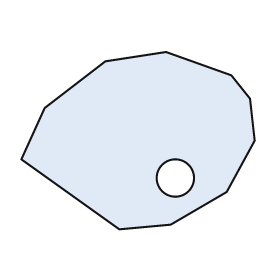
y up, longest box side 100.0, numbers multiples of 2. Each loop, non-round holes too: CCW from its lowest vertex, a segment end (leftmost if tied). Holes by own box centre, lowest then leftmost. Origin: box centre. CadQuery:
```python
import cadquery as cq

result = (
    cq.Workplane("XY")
    .moveTo(-8.0, -38.0)
    .lineTo(14.0, -36.0)
    .lineTo(38.0, -22.0)
    .lineTo(50.0, 0.0)
    .lineTo(48.0, 18.0)
    .lineTo(40.0, 28.0)
    .lineTo(12.0, 38.0)
    .lineTo(-14.0, 34.0)
    .lineTo(-40.0, 14.0)
    .lineTo(-50.0, -8.0)
    .close()
    .moveTo(16.0, -16.0)
    .circle(8.0)
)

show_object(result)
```